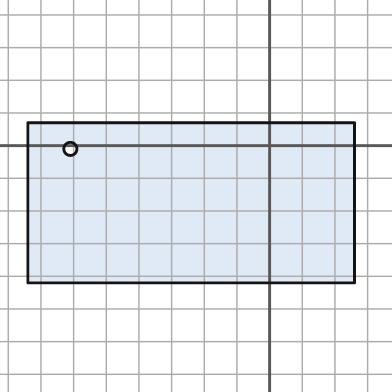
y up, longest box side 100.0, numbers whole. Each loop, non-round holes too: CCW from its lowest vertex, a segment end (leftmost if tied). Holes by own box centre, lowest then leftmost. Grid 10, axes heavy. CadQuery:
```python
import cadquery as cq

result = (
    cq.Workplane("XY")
    .moveTo(-74.0, -42.0)
    .lineTo(26.0, -42.0)
    .lineTo(26.0, 7.0)
    .lineTo(-74.0, 7.0)
    .close()
    .moveTo(-61.0, -1.0)
    .circle(2.0)
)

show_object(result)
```